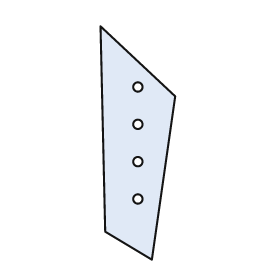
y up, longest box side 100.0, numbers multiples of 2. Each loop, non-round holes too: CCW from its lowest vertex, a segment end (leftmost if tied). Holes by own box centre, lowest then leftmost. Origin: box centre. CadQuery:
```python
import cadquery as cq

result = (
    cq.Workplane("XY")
    .moveTo(6.0, -50.0)
    .lineTo(16.0, 20.0)
    .lineTo(-16.0, 50.0)
    .lineTo(-14.0, -38.0)
    .close()
    .moveTo(0.0, -24.0)
    .circle(2.0)
    .moveTo(0.0, -8.0)
    .circle(2.0)
    .moveTo(0.0, 8.0)
    .circle(2.0)
    .moveTo(0.0, 24.0)
    .circle(2.0)
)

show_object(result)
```